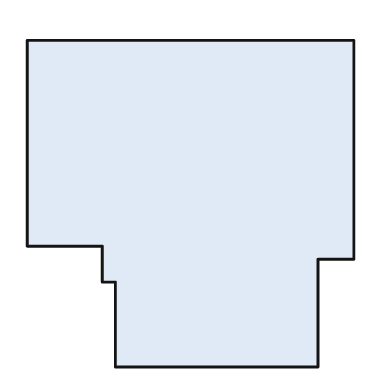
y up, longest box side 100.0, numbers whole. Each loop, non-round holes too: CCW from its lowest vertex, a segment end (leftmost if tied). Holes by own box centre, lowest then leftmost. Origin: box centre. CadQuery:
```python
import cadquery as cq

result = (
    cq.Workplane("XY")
    .moveTo(-23.0, -50.0)
    .lineTo(39.0, -50.0)
    .lineTo(39.0, -17.0)
    .lineTo(50.0, -17.0)
    .lineTo(50.0, 50.0)
    .lineTo(-50.0, 50.0)
    .lineTo(-50.0, -13.0)
    .lineTo(-27.0, -13.0)
    .lineTo(-27.0, -24.0)
    .lineTo(-23.0, -24.0)
    .close()
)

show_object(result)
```